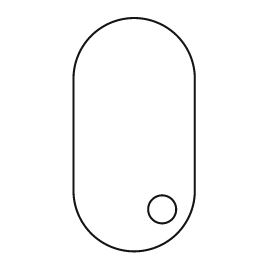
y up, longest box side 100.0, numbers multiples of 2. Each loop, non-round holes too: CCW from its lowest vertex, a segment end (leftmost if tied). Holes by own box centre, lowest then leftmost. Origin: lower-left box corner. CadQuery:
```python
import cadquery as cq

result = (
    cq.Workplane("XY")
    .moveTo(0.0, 26.0)
    .threePointArc((26.0, 0.0), (52.0, 26.0))
    .lineTo(52.0, 74.0)
    .threePointArc((26.0, 100.0), (0.0, 74.0))
    .close()
    .moveTo(38.0, 18.0)
    .circle(6.0)
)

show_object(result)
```